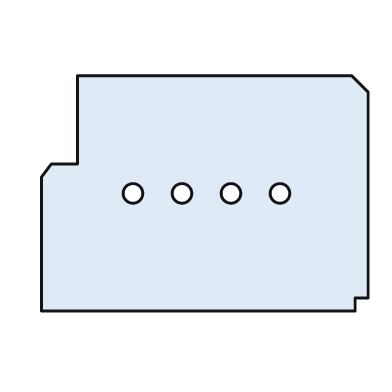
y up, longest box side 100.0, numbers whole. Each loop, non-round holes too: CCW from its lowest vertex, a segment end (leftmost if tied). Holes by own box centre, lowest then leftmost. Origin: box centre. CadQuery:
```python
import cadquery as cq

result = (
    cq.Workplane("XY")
    .moveTo(-50.0, -36.0)
    .lineTo(46.0, -36.0)
    .lineTo(46.0, -32.0)
    .lineTo(50.0, -32.0)
    .lineTo(50.0, 31.0)
    .lineTo(45.0, 36.0)
    .lineTo(-39.0, 36.0)
    .lineTo(-39.0, 9.0)
    .lineTo(-47.0, 9.0)
    .lineTo(-50.0, 5.0)
    .close()
    .moveTo(-22.0, 0.0)
    .circle(3.0)
    .moveTo(-7.0, 0.0)
    .circle(3.0)
    .moveTo(8.0, 0.0)
    .circle(3.0)
    .moveTo(23.0, 0.0)
    .circle(3.0)
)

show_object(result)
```